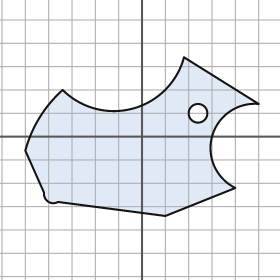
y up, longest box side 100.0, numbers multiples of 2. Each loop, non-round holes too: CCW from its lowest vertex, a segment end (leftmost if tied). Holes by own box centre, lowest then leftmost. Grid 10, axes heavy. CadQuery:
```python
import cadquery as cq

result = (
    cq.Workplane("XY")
    .moveTo(10.0, -34.0)
    .lineTo(40.0, -22.0)
    .threePointArc((30.0, 0.0), (50.0, 14.0))
    .lineTo(18.0, 34.0)
    .threePointArc((-4.0, 12.0), (-34.0, 20.0))
    .threePointArc((-44.0, 8.0), (-50.0, -6.0))
    .lineTo(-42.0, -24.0)
    .threePointArc((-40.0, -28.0), (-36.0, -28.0))
    .close()
    .moveTo(24.0, 10.0)
    .circle(4.0)
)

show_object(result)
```